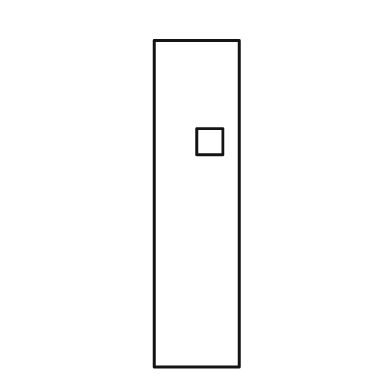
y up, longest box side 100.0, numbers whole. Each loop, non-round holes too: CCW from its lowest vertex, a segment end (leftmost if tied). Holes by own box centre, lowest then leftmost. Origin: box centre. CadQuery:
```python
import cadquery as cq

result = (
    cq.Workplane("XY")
    .moveTo(-13.0, -50.0)
    .lineTo(13.0, -50.0)
    .lineTo(13.0, 50.0)
    .lineTo(-13.0, 50.0)
    .close()
    .moveTo(0.0, 15.0)
    .lineTo(8.0, 15.0)
    .lineTo(8.0, 23.0)
    .lineTo(0.0, 23.0)
    .close()
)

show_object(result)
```